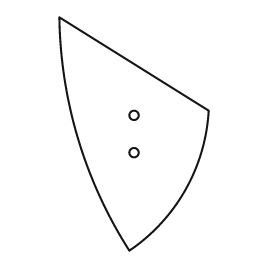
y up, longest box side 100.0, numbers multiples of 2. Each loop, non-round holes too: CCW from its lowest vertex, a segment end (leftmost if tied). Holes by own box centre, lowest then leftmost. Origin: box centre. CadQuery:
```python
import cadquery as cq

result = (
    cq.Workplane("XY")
    .moveTo(-2.0, -50.0)
    .threePointArc((22.0, -24.0), (32.0, 10.0))
    .lineTo(-32.0, 50.0)
    .threePointArc((-24.0, -2.0), (-2.0, -50.0))
    .close()
    .moveTo(0.0, -8.0)
    .circle(2.0)
    .moveTo(0.0, 8.0)
    .circle(2.0)
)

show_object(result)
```